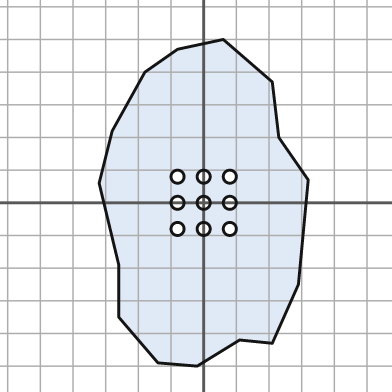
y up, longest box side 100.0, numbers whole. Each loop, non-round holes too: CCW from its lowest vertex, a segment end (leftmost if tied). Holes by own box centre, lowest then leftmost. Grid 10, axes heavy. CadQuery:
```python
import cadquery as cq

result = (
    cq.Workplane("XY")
    .moveTo(-2.0, -50.0)
    .lineTo(11.0, -42.0)
    .lineTo(21.0, -43.0)
    .lineTo(29.0, -25.0)
    .lineTo(32.0, 7.0)
    .lineTo(23.0, 20.0)
    .lineTo(21.0, 37.0)
    .lineTo(6.0, 50.0)
    .lineTo(-8.0, 47.0)
    .lineTo(-18.0, 40.0)
    .lineTo(-28.0, 22.0)
    .lineTo(-32.0, 6.0)
    .lineTo(-26.0, -19.0)
    .lineTo(-26.0, -35.0)
    .lineTo(-14.0, -49.0)
    .close()
    .moveTo(-8.0, -8.0)
    .circle(2.0)
    .moveTo(0.0, -8.0)
    .circle(2.0)
    .moveTo(8.0, -8.0)
    .circle(2.0)
    .moveTo(-8.0, 0.0)
    .circle(2.0)
    .moveTo(0.0, 0.0)
    .circle(2.0)
    .moveTo(8.0, 0.0)
    .circle(2.0)
    .moveTo(-8.0, 8.0)
    .circle(2.0)
    .moveTo(0.0, 8.0)
    .circle(2.0)
    .moveTo(8.0, 8.0)
    .circle(2.0)
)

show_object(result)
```